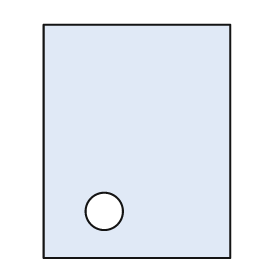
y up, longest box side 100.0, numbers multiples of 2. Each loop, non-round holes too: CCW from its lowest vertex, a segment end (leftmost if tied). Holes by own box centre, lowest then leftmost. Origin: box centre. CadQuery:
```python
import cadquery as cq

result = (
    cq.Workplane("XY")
    .moveTo(-40.0, -50.0)
    .lineTo(40.0, -50.0)
    .lineTo(40.0, 50.0)
    .lineTo(-40.0, 50.0)
    .close()
    .moveTo(-14.0, -30.0)
    .circle(8.0)
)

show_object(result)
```